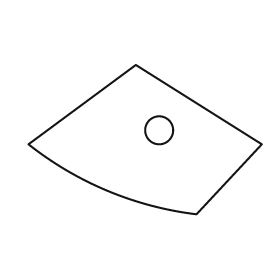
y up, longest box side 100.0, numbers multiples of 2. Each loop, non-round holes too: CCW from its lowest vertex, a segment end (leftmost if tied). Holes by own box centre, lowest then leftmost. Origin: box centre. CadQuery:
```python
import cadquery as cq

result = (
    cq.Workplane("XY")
    .moveTo(22.0, -32.0)
    .lineTo(50.0, -2.0)
    .lineTo(-4.0, 32.0)
    .lineTo(-50.0, -2.0)
    .threePointArc((-16.0, -22.0), (22.0, -32.0))
    .close()
    .moveTo(6.0, 4.0)
    .circle(6.0)
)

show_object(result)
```